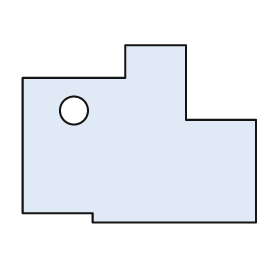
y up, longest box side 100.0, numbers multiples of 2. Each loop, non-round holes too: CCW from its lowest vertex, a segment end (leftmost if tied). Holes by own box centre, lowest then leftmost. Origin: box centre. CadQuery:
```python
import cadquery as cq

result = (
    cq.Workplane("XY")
    .moveTo(-20.0, -38.0)
    .lineTo(50.0, -38.0)
    .lineTo(50.0, 6.0)
    .lineTo(20.0, 6.0)
    .lineTo(20.0, 38.0)
    .lineTo(-6.0, 38.0)
    .lineTo(-6.0, 24.0)
    .lineTo(-50.0, 24.0)
    .lineTo(-50.0, -34.0)
    .lineTo(-20.0, -34.0)
    .close()
    .moveTo(-28.0, 10.0)
    .circle(6.0)
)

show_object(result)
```